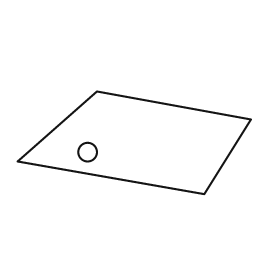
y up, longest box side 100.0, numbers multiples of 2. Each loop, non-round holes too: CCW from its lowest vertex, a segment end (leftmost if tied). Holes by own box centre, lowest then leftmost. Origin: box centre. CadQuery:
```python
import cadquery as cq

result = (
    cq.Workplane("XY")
    .moveTo(30.0, -22.0)
    .lineTo(50.0, 10.0)
    .lineTo(-16.0, 22.0)
    .lineTo(-50.0, -8.0)
    .close()
    .moveTo(-20.0, -4.0)
    .circle(4.0)
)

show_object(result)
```